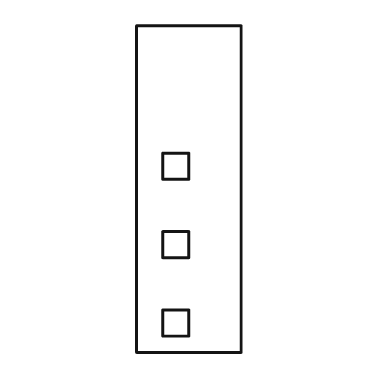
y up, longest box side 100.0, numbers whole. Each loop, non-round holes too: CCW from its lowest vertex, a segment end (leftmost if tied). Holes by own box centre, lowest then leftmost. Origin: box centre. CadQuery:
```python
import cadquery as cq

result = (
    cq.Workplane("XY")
    .moveTo(-16.0, -50.0)
    .lineTo(16.0, -50.0)
    .lineTo(16.0, 50.0)
    .lineTo(-16.0, 50.0)
    .close()
    .moveTo(-8.0, -45.0)
    .lineTo(0.0, -45.0)
    .lineTo(0.0, -37.0)
    .lineTo(-8.0, -37.0)
    .close()
    .moveTo(-8.0, -21.0)
    .lineTo(0.0, -21.0)
    .lineTo(0.0, -13.0)
    .lineTo(-8.0, -13.0)
    .close()
    .moveTo(-8.0, 3.0)
    .lineTo(0.0, 3.0)
    .lineTo(0.0, 11.0)
    .lineTo(-8.0, 11.0)
    .close()
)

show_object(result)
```